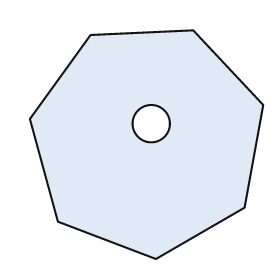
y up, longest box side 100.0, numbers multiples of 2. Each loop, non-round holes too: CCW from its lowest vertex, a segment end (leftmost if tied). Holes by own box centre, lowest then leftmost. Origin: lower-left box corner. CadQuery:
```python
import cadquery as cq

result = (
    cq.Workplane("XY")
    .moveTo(54.0, 0.0)
    .lineTo(92.0, 22.0)
    .lineTo(100.0, 66.0)
    .lineTo(70.0, 98.0)
    .lineTo(26.0, 96.0)
    .lineTo(0.0, 60.0)
    .lineTo(12.0, 16.0)
    .close()
    .moveTo(52.0, 58.0)
    .circle(8.0)
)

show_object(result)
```